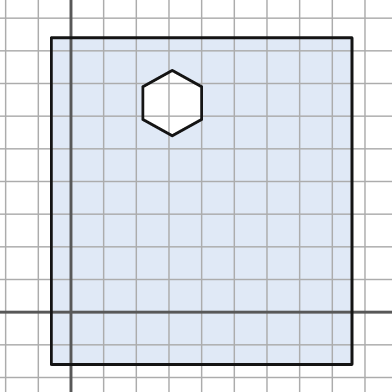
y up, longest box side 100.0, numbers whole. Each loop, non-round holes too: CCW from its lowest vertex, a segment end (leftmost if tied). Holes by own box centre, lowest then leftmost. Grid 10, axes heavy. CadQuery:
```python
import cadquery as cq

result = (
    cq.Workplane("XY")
    .moveTo(-6.0, -16.0)
    .lineTo(86.0, -16.0)
    .lineTo(86.0, 84.0)
    .lineTo(-6.0, 84.0)
    .close()
    .moveTo(31.0, 54.0)
    .lineTo(40.0, 59.0)
    .lineTo(40.0, 69.0)
    .lineTo(31.0, 74.0)
    .lineTo(22.0, 69.0)
    .lineTo(22.0, 59.0)
    .close()
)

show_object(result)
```